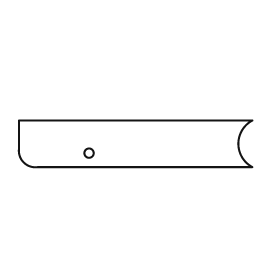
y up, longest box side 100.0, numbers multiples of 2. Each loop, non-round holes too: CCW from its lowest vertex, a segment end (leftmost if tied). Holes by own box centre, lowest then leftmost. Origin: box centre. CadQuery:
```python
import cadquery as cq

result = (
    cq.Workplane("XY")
    .moveTo(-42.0, -10.0)
    .lineTo(50.0, -10.0)
    .threePointArc((44.0, 0.0), (50.0, 10.0))
    .lineTo(-50.0, 10.0)
    .lineTo(-50.0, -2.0)
    .threePointArc((-48.0, -8.0), (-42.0, -10.0))
    .close()
    .moveTo(-20.0, -4.0)
    .circle(2.0)
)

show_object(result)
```